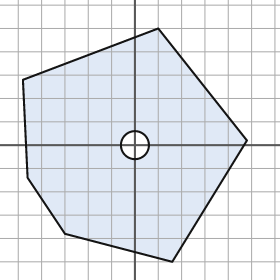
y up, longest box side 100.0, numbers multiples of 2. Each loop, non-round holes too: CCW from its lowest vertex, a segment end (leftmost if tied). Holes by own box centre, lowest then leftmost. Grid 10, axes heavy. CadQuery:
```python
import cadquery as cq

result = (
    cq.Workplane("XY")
    .moveTo(16.0, -50.0)
    .lineTo(48.0, 2.0)
    .lineTo(10.0, 50.0)
    .lineTo(-48.0, 28.0)
    .lineTo(-46.0, -14.0)
    .lineTo(-30.0, -38.0)
    .close()
    .moveTo(0.0, 0.0)
    .circle(6.0)
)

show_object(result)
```